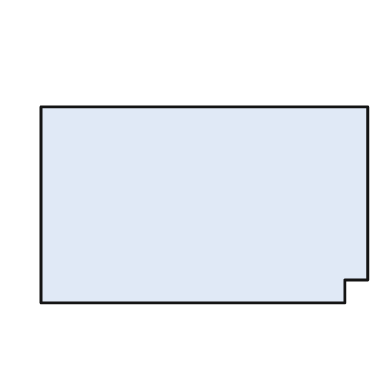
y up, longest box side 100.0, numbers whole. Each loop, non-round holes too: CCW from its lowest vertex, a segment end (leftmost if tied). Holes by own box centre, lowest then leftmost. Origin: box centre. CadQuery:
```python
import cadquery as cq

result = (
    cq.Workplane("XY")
    .moveTo(-50.0, -30.0)
    .lineTo(43.0, -30.0)
    .lineTo(43.0, -23.0)
    .lineTo(50.0, -23.0)
    .lineTo(50.0, 30.0)
    .lineTo(-50.0, 30.0)
    .close()
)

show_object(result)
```